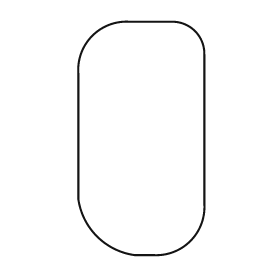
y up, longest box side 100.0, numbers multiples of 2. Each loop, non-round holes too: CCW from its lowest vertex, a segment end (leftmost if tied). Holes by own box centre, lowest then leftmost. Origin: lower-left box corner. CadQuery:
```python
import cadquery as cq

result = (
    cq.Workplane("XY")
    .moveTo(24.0, 0.0)
    .lineTo(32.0, 0.0)
    .threePointArc((48.0, 6.0), (54.0, 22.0))
    .lineTo(54.0, 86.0)
    .threePointArc((50.0, 96.0), (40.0, 100.0))
    .lineTo(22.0, 100.0)
    .threePointArc((6.0, 94.0), (0.0, 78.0))
    .lineTo(0.0, 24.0)
    .threePointArc((8.0, 8.0), (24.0, 0.0))
    .close()
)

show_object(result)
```